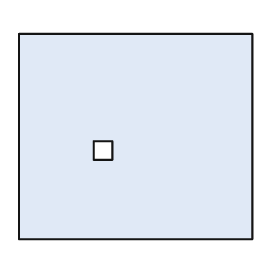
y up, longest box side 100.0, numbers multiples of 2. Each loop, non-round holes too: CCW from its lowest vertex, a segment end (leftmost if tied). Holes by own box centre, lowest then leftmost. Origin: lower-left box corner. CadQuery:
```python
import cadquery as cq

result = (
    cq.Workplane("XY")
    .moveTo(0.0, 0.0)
    .lineTo(100.0, 0.0)
    .lineTo(100.0, 88.0)
    .lineTo(0.0, 88.0)
    .close()
    .moveTo(32.0, 34.0)
    .lineTo(40.0, 34.0)
    .lineTo(40.0, 42.0)
    .lineTo(32.0, 42.0)
    .close()
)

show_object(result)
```